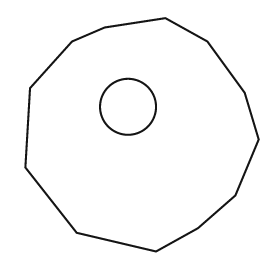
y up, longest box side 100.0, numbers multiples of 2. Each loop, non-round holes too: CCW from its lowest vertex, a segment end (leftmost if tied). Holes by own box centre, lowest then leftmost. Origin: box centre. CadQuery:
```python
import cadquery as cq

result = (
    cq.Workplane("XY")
    .moveTo(6.0, -50.0)
    .lineTo(24.0, -40.0)
    .lineTo(40.0, -26.0)
    .lineTo(50.0, -2.0)
    .lineTo(44.0, 18.0)
    .lineTo(28.0, 40.0)
    .lineTo(10.0, 50.0)
    .lineTo(-16.0, 46.0)
    .lineTo(-30.0, 40.0)
    .lineTo(-48.0, 20.0)
    .lineTo(-50.0, -14.0)
    .lineTo(-28.0, -42.0)
    .close()
    .moveTo(-6.0, 12.0)
    .circle(12.0)
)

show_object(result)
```